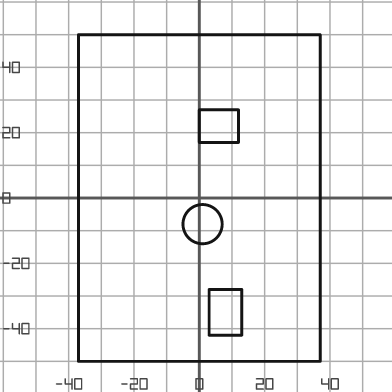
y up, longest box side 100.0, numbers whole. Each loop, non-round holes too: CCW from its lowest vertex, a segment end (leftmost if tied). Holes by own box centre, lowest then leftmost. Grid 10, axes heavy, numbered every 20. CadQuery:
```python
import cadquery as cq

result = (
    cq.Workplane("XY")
    .moveTo(-37.0, -50.0)
    .lineTo(37.0, -50.0)
    .lineTo(37.0, 50.0)
    .lineTo(-37.0, 50.0)
    .close()
    .moveTo(3.0, -42.0)
    .lineTo(13.0, -42.0)
    .lineTo(13.0, -28.0)
    .lineTo(3.0, -28.0)
    .close()
    .moveTo(1.0, -8.0)
    .circle(6.0)
    .moveTo(0.0, 17.0)
    .lineTo(12.0, 17.0)
    .lineTo(12.0, 27.0)
    .lineTo(0.0, 27.0)
    .close()
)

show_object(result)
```